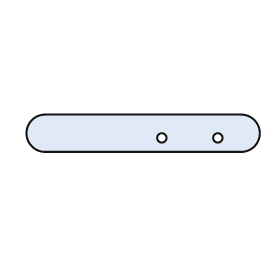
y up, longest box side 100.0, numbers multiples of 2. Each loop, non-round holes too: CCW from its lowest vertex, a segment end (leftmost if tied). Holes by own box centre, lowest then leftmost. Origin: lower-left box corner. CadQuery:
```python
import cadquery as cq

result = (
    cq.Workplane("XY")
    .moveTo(8.0, 0.0)
    .lineTo(92.0, 0.0)
    .threePointArc((100.0, 8.0), (92.0, 16.0))
    .lineTo(8.0, 16.0)
    .threePointArc((0.0, 8.0), (8.0, 0.0))
    .close()
    .moveTo(58.0, 6.0)
    .circle(2.0)
    .moveTo(82.0, 6.0)
    .circle(2.0)
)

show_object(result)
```